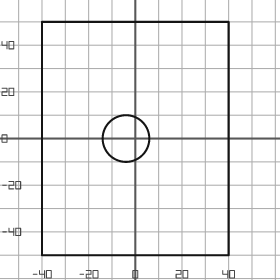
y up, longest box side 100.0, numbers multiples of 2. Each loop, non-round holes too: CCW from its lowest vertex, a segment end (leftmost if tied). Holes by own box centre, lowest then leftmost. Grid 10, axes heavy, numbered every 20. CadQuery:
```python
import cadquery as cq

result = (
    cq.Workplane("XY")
    .moveTo(-40.0, -50.0)
    .lineTo(40.0, -50.0)
    .lineTo(40.0, 50.0)
    .lineTo(-40.0, 50.0)
    .close()
    .moveTo(-4.0, 0.0)
    .circle(10.0)
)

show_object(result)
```